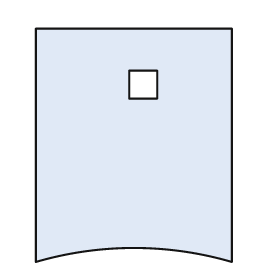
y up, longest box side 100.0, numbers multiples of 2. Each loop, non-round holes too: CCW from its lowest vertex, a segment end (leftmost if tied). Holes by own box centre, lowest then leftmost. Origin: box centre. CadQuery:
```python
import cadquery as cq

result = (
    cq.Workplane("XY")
    .moveTo(-42.0, -50.0)
    .threePointArc((0.0, -44.0), (42.0, -50.0))
    .lineTo(42.0, 50.0)
    .lineTo(-42.0, 50.0)
    .close()
    .moveTo(-2.0, 20.0)
    .lineTo(10.0, 20.0)
    .lineTo(10.0, 32.0)
    .lineTo(-2.0, 32.0)
    .close()
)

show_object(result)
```